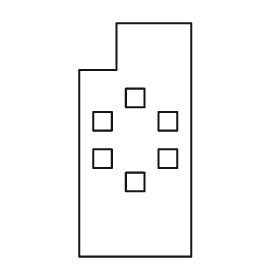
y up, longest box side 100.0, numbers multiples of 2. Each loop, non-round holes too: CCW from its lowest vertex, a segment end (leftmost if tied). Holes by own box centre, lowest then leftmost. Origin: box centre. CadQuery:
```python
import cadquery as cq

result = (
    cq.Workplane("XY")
    .moveTo(-24.0, -50.0)
    .lineTo(24.0, -50.0)
    .lineTo(24.0, 50.0)
    .lineTo(-8.0, 50.0)
    .lineTo(-8.0, 30.0)
    .lineTo(-24.0, 30.0)
    .close()
    .moveTo(-4.0, -22.0)
    .lineTo(4.0, -22.0)
    .lineTo(4.0, -14.0)
    .lineTo(-4.0, -14.0)
    .close()
    .moveTo(-18.0, -12.0)
    .lineTo(-10.0, -12.0)
    .lineTo(-10.0, -4.0)
    .lineTo(-18.0, -4.0)
    .close()
    .moveTo(10.0, -12.0)
    .lineTo(18.0, -12.0)
    .lineTo(18.0, -4.0)
    .lineTo(10.0, -4.0)
    .close()
    .moveTo(-18.0, 4.0)
    .lineTo(-10.0, 4.0)
    .lineTo(-10.0, 12.0)
    .lineTo(-18.0, 12.0)
    .close()
    .moveTo(10.0, 4.0)
    .lineTo(18.0, 4.0)
    .lineTo(18.0, 12.0)
    .lineTo(10.0, 12.0)
    .close()
    .moveTo(-4.0, 14.0)
    .lineTo(4.0, 14.0)
    .lineTo(4.0, 22.0)
    .lineTo(-4.0, 22.0)
    .close()
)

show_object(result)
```